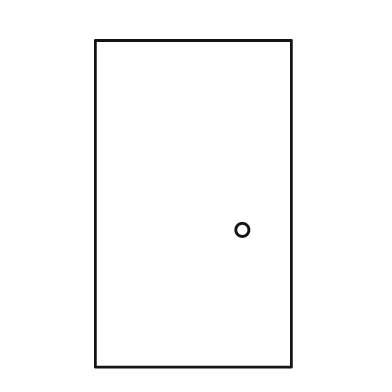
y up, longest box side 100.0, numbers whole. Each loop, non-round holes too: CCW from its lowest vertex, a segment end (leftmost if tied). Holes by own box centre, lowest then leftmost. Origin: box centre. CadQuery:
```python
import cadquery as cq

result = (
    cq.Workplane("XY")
    .moveTo(-30.0, -50.0)
    .lineTo(30.0, -50.0)
    .lineTo(30.0, 50.0)
    .lineTo(-30.0, 50.0)
    .close()
    .moveTo(15.0, -8.0)
    .circle(2.0)
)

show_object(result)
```